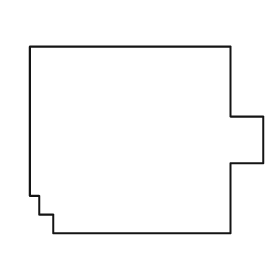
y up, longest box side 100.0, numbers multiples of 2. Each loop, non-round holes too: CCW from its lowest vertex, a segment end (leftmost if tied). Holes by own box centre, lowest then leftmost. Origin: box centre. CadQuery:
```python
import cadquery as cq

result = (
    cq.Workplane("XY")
    .moveTo(-40.0, -40.0)
    .lineTo(36.0, -40.0)
    .lineTo(36.0, -10.0)
    .lineTo(50.0, -10.0)
    .lineTo(50.0, 10.0)
    .lineTo(36.0, 10.0)
    .lineTo(36.0, 40.0)
    .lineTo(-50.0, 40.0)
    .lineTo(-50.0, -24.0)
    .lineTo(-46.0, -24.0)
    .lineTo(-46.0, -32.0)
    .lineTo(-40.0, -32.0)
    .close()
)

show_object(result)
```